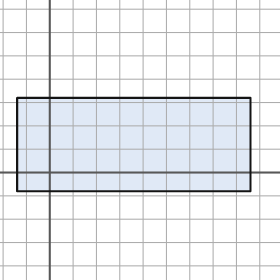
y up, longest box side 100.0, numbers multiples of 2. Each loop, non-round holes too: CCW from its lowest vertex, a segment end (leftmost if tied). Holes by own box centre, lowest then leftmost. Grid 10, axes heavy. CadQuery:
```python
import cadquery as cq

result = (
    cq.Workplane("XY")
    .moveTo(-14.0, -8.0)
    .lineTo(86.0, -8.0)
    .lineTo(86.0, 32.0)
    .lineTo(-14.0, 32.0)
    .close()
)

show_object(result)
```